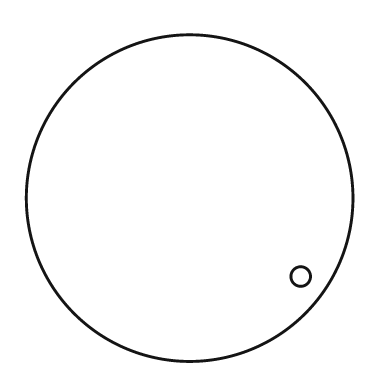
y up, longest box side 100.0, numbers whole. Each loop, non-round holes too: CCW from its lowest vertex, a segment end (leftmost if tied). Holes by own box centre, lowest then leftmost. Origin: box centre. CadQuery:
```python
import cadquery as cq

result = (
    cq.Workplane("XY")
    .moveTo(0.0, 0.0)
    .circle(50.0)
    .moveTo(34.0, -24.0)
    .circle(3.0)
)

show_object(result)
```